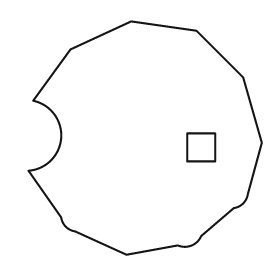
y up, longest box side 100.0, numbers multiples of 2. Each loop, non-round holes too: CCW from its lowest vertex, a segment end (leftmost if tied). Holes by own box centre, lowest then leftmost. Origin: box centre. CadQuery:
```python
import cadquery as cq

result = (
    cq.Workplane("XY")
    .moveTo(-8.0, -50.0)
    .lineTo(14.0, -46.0)
    .threePointArc((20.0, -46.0), (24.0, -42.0))
    .lineTo(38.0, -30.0)
    .threePointArc((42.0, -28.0), (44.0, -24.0))
    .lineTo(50.0, -2.0)
    .lineTo(42.0, 26.0)
    .lineTo(22.0, 46.0)
    .lineTo(-6.0, 50.0)
    .lineTo(-32.0, 38.0)
    .lineTo(-48.0, 16.0)
    .threePointArc((-36.0, 0.0), (-50.0, -14.0))
    .lineTo(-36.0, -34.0)
    .threePointArc((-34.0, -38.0), (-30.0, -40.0))
    .close()
    .moveTo(18.0, -10.0)
    .lineTo(30.0, -10.0)
    .lineTo(30.0, 2.0)
    .lineTo(18.0, 2.0)
    .close()
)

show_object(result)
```